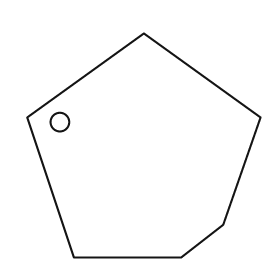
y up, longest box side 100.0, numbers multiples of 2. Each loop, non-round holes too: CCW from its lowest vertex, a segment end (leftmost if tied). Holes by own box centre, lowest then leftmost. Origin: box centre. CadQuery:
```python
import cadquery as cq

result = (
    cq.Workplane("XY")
    .moveTo(-30.0, -48.0)
    .lineTo(16.0, -48.0)
    .lineTo(34.0, -34.0)
    .lineTo(50.0, 12.0)
    .lineTo(0.0, 48.0)
    .lineTo(-50.0, 12.0)
    .close()
    .moveTo(-36.0, 10.0)
    .circle(4.0)
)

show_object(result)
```